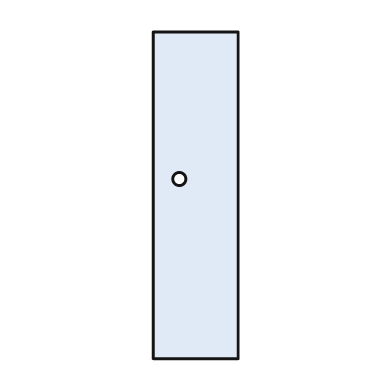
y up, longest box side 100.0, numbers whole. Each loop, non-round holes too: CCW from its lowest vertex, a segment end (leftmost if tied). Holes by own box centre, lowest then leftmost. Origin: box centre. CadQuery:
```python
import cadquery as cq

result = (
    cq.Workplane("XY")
    .moveTo(-13.0, -50.0)
    .lineTo(13.0, -50.0)
    .lineTo(13.0, 50.0)
    .lineTo(-13.0, 50.0)
    .close()
    .moveTo(-5.0, 5.0)
    .circle(2.0)
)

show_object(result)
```